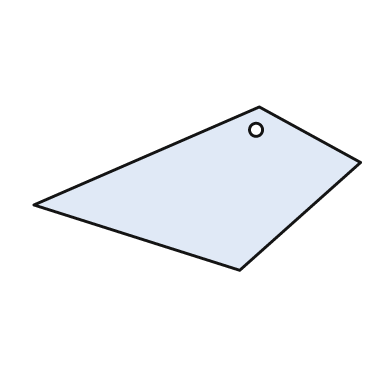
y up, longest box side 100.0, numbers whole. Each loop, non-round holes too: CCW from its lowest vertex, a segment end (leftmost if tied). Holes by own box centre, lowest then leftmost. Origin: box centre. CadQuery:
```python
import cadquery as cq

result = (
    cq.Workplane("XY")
    .moveTo(13.0, -25.0)
    .lineTo(50.0, 8.0)
    .lineTo(19.0, 25.0)
    .lineTo(-50.0, -5.0)
    .close()
    .moveTo(18.0, 18.0)
    .circle(2.0)
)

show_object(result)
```